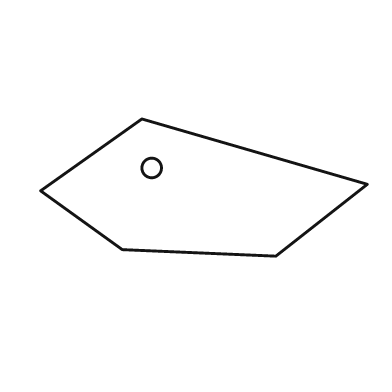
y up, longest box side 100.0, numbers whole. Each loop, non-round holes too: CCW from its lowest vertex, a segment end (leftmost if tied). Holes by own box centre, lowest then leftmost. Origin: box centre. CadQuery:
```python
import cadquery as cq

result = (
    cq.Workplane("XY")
    .moveTo(22.0, -21.0)
    .lineTo(50.0, 1.0)
    .lineTo(-19.0, 21.0)
    .lineTo(-50.0, -1.0)
    .lineTo(-25.0, -19.0)
    .close()
    .moveTo(-16.0, 6.0)
    .circle(3.0)
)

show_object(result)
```